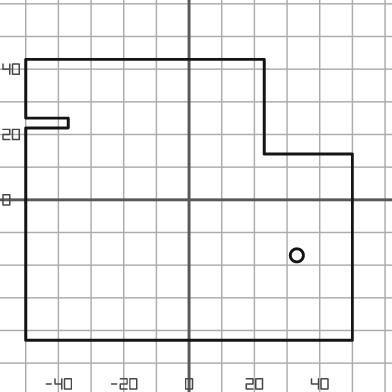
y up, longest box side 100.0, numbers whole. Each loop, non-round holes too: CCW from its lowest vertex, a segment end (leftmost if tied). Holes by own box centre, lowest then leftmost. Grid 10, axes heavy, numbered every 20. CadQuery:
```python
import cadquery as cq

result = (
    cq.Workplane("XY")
    .moveTo(-50.0, -43.0)
    .lineTo(50.0, -43.0)
    .lineTo(50.0, 14.0)
    .lineTo(23.0, 14.0)
    .lineTo(23.0, 43.0)
    .lineTo(-50.0, 43.0)
    .lineTo(-50.0, 25.0)
    .lineTo(-37.0, 25.0)
    .lineTo(-37.0, 22.0)
    .lineTo(-50.0, 22.0)
    .close()
    .moveTo(33.0, -17.0)
    .circle(2.0)
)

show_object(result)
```